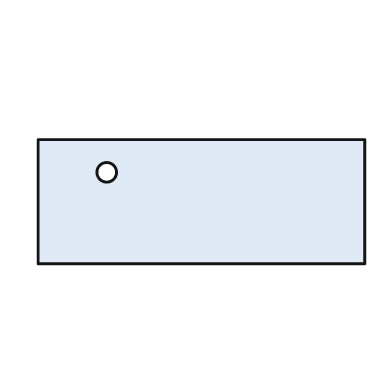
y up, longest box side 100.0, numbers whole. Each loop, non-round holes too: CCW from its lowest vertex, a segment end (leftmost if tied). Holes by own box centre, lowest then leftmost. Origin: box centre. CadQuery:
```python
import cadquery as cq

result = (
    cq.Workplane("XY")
    .moveTo(-50.0, -19.0)
    .lineTo(50.0, -19.0)
    .lineTo(50.0, 19.0)
    .lineTo(-50.0, 19.0)
    .close()
    .moveTo(-29.0, 9.0)
    .circle(3.0)
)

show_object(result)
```